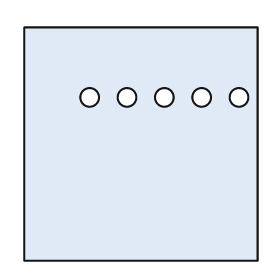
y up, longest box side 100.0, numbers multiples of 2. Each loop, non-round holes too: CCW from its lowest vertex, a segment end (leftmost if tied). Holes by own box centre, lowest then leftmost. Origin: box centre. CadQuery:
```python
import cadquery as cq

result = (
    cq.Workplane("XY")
    .moveTo(-50.0, -50.0)
    .lineTo(50.0, -50.0)
    .lineTo(50.0, 50.0)
    .lineTo(-50.0, 50.0)
    .close()
    .moveTo(-22.0, 20.0)
    .circle(4.0)
    .moveTo(-6.0, 20.0)
    .circle(4.0)
    .moveTo(10.0, 20.0)
    .circle(4.0)
    .moveTo(26.0, 20.0)
    .circle(4.0)
    .moveTo(42.0, 20.0)
    .circle(4.0)
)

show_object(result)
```